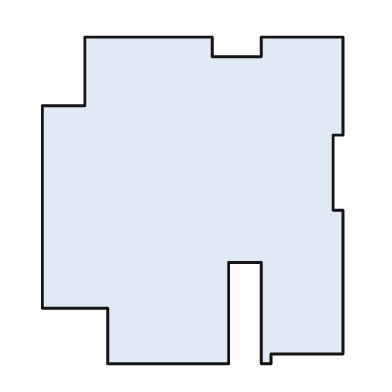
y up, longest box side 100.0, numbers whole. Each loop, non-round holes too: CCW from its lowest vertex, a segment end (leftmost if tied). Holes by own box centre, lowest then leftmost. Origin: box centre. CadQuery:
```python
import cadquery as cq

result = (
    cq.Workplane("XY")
    .moveTo(-26.0, -50.0)
    .lineTo(11.0, -50.0)
    .lineTo(11.0, -19.0)
    .lineTo(21.0, -19.0)
    .lineTo(21.0, -50.0)
    .lineTo(24.0, -50.0)
    .lineTo(24.0, -47.0)
    .lineTo(46.0, -47.0)
    .lineTo(46.0, -3.0)
    .lineTo(43.0, -3.0)
    .lineTo(43.0, 20.0)
    .lineTo(46.0, 20.0)
    .lineTo(46.0, 50.0)
    .lineTo(21.0, 50.0)
    .lineTo(21.0, 44.0)
    .lineTo(6.0, 44.0)
    .lineTo(6.0, 50.0)
    .lineTo(-33.0, 50.0)
    .lineTo(-33.0, 29.0)
    .lineTo(-46.0, 29.0)
    .lineTo(-46.0, -33.0)
    .lineTo(-26.0, -33.0)
    .close()
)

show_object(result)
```